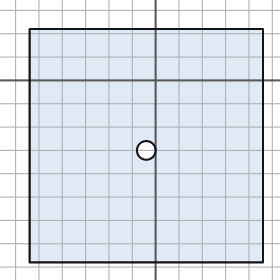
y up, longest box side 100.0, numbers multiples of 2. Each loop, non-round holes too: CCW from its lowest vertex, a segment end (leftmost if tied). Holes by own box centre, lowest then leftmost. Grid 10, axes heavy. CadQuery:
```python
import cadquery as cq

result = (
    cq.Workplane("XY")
    .moveTo(-54.0, -78.0)
    .lineTo(46.0, -78.0)
    .lineTo(46.0, 22.0)
    .lineTo(-54.0, 22.0)
    .close()
    .moveTo(-4.0, -30.0)
    .circle(4.0)
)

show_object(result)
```